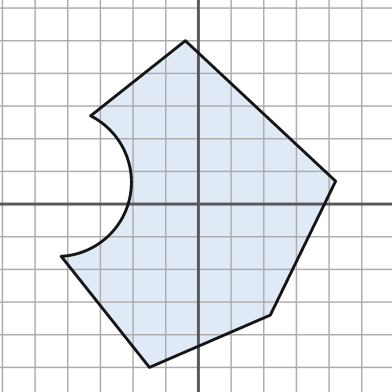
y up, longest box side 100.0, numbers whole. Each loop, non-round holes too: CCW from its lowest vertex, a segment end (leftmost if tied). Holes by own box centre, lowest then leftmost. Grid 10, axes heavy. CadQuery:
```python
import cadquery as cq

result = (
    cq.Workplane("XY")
    .moveTo(-15.0, -50.0)
    .lineTo(22.0, -34.0)
    .lineTo(42.0, 7.0)
    .lineTo(-4.0, 50.0)
    .lineTo(-33.0, 27.0)
    .threePointArc((-21.0, 2.0), (-42.0, -16.0))
    .close()
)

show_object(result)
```